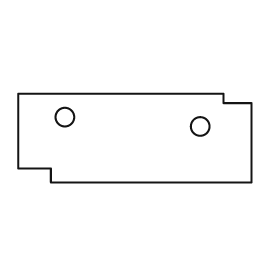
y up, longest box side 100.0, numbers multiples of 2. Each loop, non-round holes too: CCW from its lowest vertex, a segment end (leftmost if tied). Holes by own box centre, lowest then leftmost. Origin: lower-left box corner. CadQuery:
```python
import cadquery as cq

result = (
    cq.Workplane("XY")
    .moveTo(14.0, 0.0)
    .lineTo(100.0, 0.0)
    .lineTo(100.0, 34.0)
    .lineTo(88.0, 34.0)
    .lineTo(88.0, 38.0)
    .lineTo(0.0, 38.0)
    .lineTo(0.0, 6.0)
    .lineTo(14.0, 6.0)
    .close()
    .moveTo(78.0, 24.0)
    .circle(4.0)
    .moveTo(20.0, 28.0)
    .circle(4.0)
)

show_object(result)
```